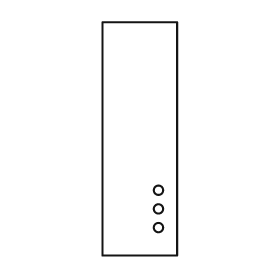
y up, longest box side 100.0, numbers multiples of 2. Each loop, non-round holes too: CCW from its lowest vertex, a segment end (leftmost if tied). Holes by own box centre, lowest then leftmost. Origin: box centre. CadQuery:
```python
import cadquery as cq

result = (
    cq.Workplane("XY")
    .moveTo(-16.0, -50.0)
    .lineTo(16.0, -50.0)
    .lineTo(16.0, 50.0)
    .lineTo(-16.0, 50.0)
    .close()
    .moveTo(8.0, -38.0)
    .circle(2.0)
    .moveTo(8.0, -30.0)
    .circle(2.0)
    .moveTo(8.0, -22.0)
    .circle(2.0)
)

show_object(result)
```